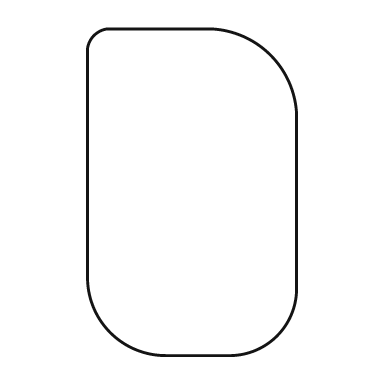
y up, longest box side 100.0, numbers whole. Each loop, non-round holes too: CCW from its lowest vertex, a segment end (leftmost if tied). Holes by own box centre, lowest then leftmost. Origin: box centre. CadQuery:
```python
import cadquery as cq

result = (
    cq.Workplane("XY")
    .moveTo(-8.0, -50.0)
    .lineTo(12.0, -50.0)
    .threePointArc((26.0, -44.0), (32.0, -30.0))
    .lineTo(32.0, 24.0)
    .threePointArc((24.0, 42.0), (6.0, 50.0))
    .lineTo(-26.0, 50.0)
    .threePointArc((-30.0, 48.0), (-32.0, 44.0))
    .lineTo(-32.0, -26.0)
    .threePointArc((-25.0, -43.0), (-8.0, -50.0))
    .close()
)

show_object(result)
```